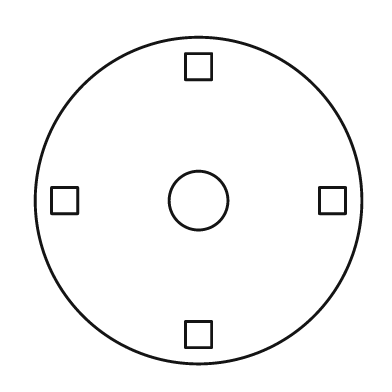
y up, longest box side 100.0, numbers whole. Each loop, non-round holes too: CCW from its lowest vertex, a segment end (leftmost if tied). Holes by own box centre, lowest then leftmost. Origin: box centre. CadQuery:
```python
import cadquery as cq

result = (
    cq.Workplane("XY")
    .moveTo(0.0, 0.0)
    .circle(50.0)
    .moveTo(-4.0, -45.0)
    .lineTo(4.0, -45.0)
    .lineTo(4.0, -37.0)
    .lineTo(-4.0, -37.0)
    .close()
    .moveTo(-45.0, -4.0)
    .lineTo(-37.0, -4.0)
    .lineTo(-37.0, 4.0)
    .lineTo(-45.0, 4.0)
    .close()
    .moveTo(0.0, 0.0)
    .circle(9.0)
    .moveTo(37.0, -4.0)
    .lineTo(45.0, -4.0)
    .lineTo(45.0, 4.0)
    .lineTo(37.0, 4.0)
    .close()
    .moveTo(-4.0, 37.0)
    .lineTo(4.0, 37.0)
    .lineTo(4.0, 45.0)
    .lineTo(-4.0, 45.0)
    .close()
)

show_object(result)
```